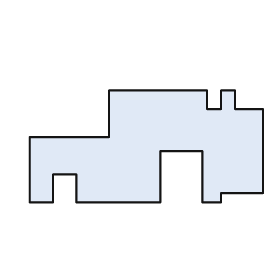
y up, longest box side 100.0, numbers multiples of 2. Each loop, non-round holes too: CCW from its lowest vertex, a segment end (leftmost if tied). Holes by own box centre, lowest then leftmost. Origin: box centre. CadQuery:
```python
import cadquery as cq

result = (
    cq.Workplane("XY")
    .moveTo(-50.0, -24.0)
    .lineTo(-40.0, -24.0)
    .lineTo(-40.0, -12.0)
    .lineTo(-30.0, -12.0)
    .lineTo(-30.0, -24.0)
    .lineTo(6.0, -24.0)
    .lineTo(6.0, -2.0)
    .lineTo(24.0, -2.0)
    .lineTo(24.0, -24.0)
    .lineTo(32.0, -24.0)
    .lineTo(32.0, -20.0)
    .lineTo(50.0, -20.0)
    .lineTo(50.0, 16.0)
    .lineTo(38.0, 16.0)
    .lineTo(38.0, 24.0)
    .lineTo(32.0, 24.0)
    .lineTo(32.0, 16.0)
    .lineTo(26.0, 16.0)
    .lineTo(26.0, 24.0)
    .lineTo(-16.0, 24.0)
    .lineTo(-16.0, 4.0)
    .lineTo(-50.0, 4.0)
    .close()
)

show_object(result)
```